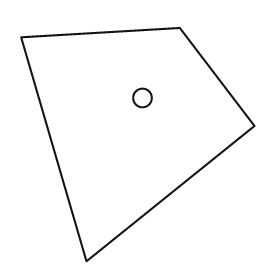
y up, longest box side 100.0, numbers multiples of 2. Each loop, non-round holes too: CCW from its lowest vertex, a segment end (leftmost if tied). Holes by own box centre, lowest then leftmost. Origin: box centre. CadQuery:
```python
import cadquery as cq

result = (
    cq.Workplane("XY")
    .moveTo(-22.0, -50.0)
    .lineTo(50.0, 8.0)
    .lineTo(18.0, 50.0)
    .lineTo(-50.0, 46.0)
    .close()
    .moveTo(2.0, 20.0)
    .circle(4.0)
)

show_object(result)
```